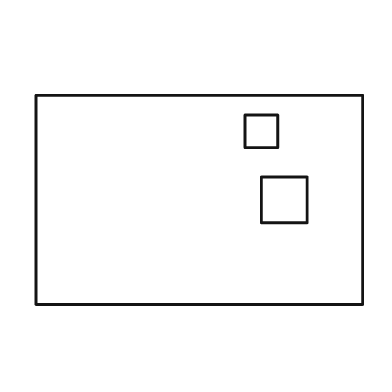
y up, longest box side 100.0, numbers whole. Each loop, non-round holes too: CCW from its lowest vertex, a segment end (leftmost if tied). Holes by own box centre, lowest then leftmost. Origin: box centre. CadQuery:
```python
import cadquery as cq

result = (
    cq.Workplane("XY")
    .moveTo(-50.0, -32.0)
    .lineTo(50.0, -32.0)
    .lineTo(50.0, 32.0)
    .lineTo(-50.0, 32.0)
    .close()
    .moveTo(19.0, -7.0)
    .lineTo(33.0, -7.0)
    .lineTo(33.0, 7.0)
    .lineTo(19.0, 7.0)
    .close()
    .moveTo(14.0, 16.0)
    .lineTo(24.0, 16.0)
    .lineTo(24.0, 26.0)
    .lineTo(14.0, 26.0)
    .close()
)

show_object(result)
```